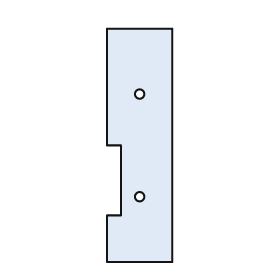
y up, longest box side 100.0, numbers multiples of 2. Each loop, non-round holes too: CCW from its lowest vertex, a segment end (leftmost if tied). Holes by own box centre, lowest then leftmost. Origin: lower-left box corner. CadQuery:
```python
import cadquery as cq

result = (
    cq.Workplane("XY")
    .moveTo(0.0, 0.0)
    .lineTo(28.0, 0.0)
    .lineTo(28.0, 100.0)
    .lineTo(0.0, 100.0)
    .lineTo(0.0, 50.0)
    .lineTo(6.0, 50.0)
    .lineTo(6.0, 20.0)
    .lineTo(0.0, 20.0)
    .close()
    .moveTo(14.0, 28.0)
    .circle(2.0)
    .moveTo(14.0, 72.0)
    .circle(2.0)
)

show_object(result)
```